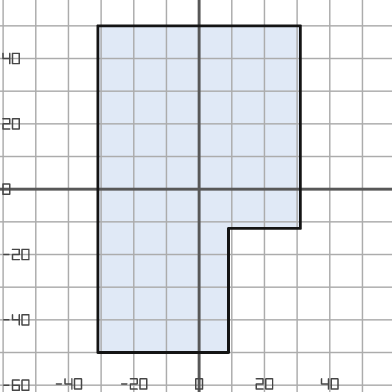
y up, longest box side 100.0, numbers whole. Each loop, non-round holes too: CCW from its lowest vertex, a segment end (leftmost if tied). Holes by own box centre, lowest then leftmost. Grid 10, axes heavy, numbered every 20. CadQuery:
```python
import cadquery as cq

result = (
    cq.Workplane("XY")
    .moveTo(-31.0, -50.0)
    .lineTo(9.0, -50.0)
    .lineTo(9.0, -12.0)
    .lineTo(31.0, -12.0)
    .lineTo(31.0, 50.0)
    .lineTo(-31.0, 50.0)
    .close()
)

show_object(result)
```